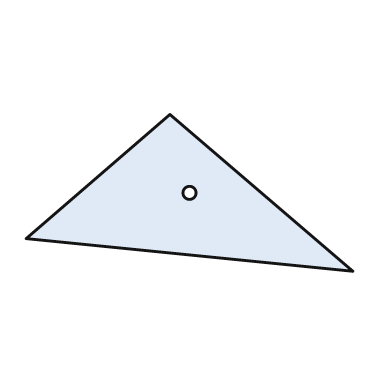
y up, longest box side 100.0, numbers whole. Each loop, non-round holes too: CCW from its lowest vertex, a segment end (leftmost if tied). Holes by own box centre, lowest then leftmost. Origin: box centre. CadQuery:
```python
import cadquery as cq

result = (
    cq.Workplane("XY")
    .moveTo(50.0, -24.0)
    .lineTo(-6.0, 24.0)
    .lineTo(-50.0, -14.0)
    .close()
    .moveTo(0.0, 0.0)
    .circle(2.0)
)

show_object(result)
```